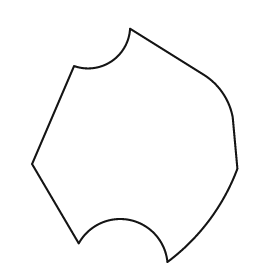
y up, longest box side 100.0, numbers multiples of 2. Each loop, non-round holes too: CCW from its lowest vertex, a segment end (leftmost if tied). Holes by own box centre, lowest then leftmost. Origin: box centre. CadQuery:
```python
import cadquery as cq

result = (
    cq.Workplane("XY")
    .moveTo(14.0, -50.0)
    .threePointArc((32.0, -32.0), (44.0, -10.0))
    .lineTo(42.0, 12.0)
    .threePointArc((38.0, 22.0), (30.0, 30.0))
    .lineTo(-2.0, 50.0)
    .threePointArc((-10.0, 36.0), (-26.0, 34.0))
    .lineTo(-44.0, -8.0)
    .lineTo(-24.0, -42.0)
    .threePointArc((-2.0, -32.0), (14.0, -50.0))
    .close()
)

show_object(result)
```